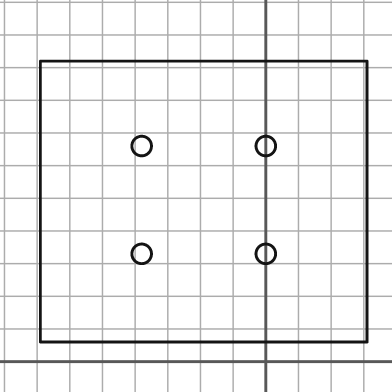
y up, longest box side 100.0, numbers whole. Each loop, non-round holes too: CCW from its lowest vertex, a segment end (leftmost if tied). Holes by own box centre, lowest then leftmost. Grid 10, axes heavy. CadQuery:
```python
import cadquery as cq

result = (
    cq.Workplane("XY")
    .moveTo(-69.0, 6.0)
    .lineTo(31.0, 6.0)
    .lineTo(31.0, 92.0)
    .lineTo(-69.0, 92.0)
    .close()
    .moveTo(-38.0, 33.0)
    .circle(3.0)
    .moveTo(0.0, 33.0)
    .circle(3.0)
    .moveTo(-38.0, 66.0)
    .circle(3.0)
    .moveTo(0.0, 66.0)
    .circle(3.0)
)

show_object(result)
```